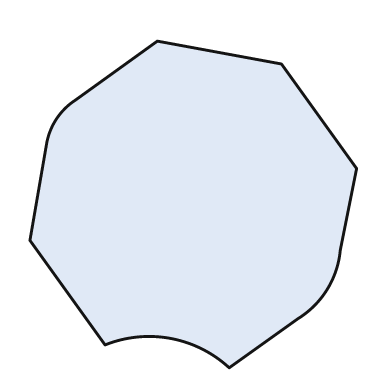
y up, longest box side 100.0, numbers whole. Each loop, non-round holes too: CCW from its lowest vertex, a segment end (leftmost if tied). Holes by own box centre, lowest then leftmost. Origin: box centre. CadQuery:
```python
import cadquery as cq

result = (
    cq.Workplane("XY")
    .moveTo(11.0, -50.0)
    .lineTo(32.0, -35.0)
    .threePointArc((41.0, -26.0), (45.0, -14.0))
    .lineTo(50.0, 11.0)
    .lineTo(27.0, 43.0)
    .lineTo(-11.0, 50.0)
    .lineTo(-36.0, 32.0)
    .threePointArc((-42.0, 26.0), (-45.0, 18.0))
    .lineTo(-50.0, -11.0)
    .lineTo(-27.0, -43.0)
    .threePointArc((-7.0, -41.0), (11.0, -50.0))
    .close()
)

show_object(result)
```